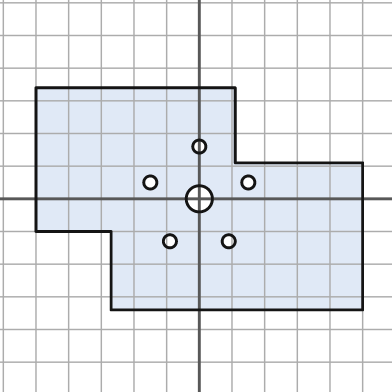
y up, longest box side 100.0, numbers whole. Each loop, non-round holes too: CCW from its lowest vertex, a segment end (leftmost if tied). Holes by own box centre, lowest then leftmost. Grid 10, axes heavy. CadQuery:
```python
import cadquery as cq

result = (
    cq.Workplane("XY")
    .moveTo(-27.0, -34.0)
    .lineTo(50.0, -34.0)
    .lineTo(50.0, 11.0)
    .lineTo(11.0, 11.0)
    .lineTo(11.0, 34.0)
    .lineTo(-50.0, 34.0)
    .lineTo(-50.0, -10.0)
    .lineTo(-27.0, -10.0)
    .close()
    .moveTo(-9.0, -13.0)
    .circle(2.0)
    .moveTo(9.0, -13.0)
    .circle(2.0)
    .moveTo(0.0, 0.0)
    .circle(4.0)
    .moveTo(-15.0, 5.0)
    .circle(2.0)
    .moveTo(15.0, 5.0)
    .circle(2.0)
    .moveTo(0.0, 16.0)
    .circle(2.0)
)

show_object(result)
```